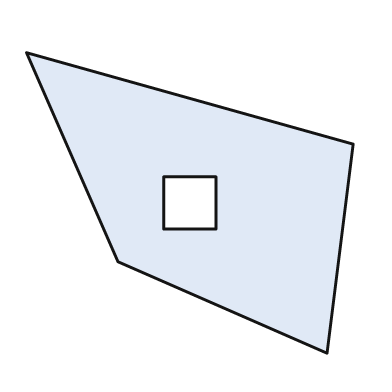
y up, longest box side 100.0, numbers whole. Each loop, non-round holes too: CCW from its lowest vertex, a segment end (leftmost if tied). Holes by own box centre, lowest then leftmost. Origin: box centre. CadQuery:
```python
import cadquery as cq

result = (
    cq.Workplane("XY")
    .moveTo(42.0, -46.0)
    .lineTo(50.0, 18.0)
    .lineTo(-50.0, 46.0)
    .lineTo(-22.0, -18.0)
    .close()
    .moveTo(-8.0, -8.0)
    .lineTo(8.0, -8.0)
    .lineTo(8.0, 8.0)
    .lineTo(-8.0, 8.0)
    .close()
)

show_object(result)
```